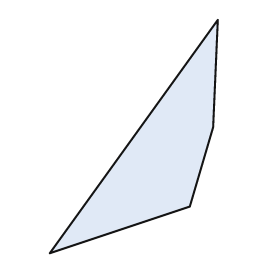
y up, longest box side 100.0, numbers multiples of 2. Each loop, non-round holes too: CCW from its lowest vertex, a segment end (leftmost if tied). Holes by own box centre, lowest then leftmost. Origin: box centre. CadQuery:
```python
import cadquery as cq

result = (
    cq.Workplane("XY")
    .moveTo(-36.0, -50.0)
    .lineTo(24.0, -30.0)
    .lineTo(34.0, 4.0)
    .lineTo(36.0, 50.0)
    .close()
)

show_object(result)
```